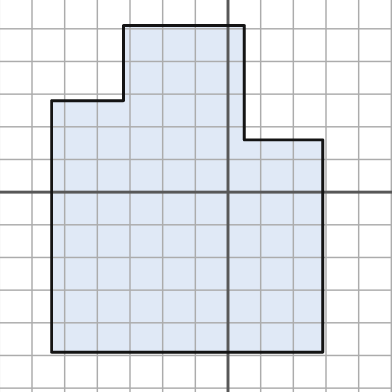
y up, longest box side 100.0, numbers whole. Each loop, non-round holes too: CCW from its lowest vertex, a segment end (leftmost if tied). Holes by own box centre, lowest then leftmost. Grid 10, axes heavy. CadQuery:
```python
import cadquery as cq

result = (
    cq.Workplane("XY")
    .moveTo(-54.0, -49.0)
    .lineTo(29.0, -49.0)
    .lineTo(29.0, 16.0)
    .lineTo(5.0, 16.0)
    .lineTo(5.0, 51.0)
    .lineTo(-32.0, 51.0)
    .lineTo(-32.0, 28.0)
    .lineTo(-54.0, 28.0)
    .close()
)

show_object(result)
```